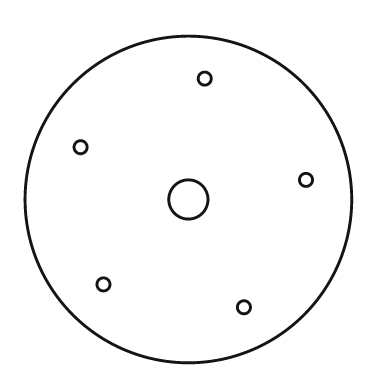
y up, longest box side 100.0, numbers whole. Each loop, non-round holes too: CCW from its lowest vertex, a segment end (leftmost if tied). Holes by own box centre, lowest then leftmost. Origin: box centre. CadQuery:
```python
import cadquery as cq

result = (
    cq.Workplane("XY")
    .moveTo(0.0, 0.0)
    .circle(50.0)
    .moveTo(17.0, -33.0)
    .circle(2.0)
    .moveTo(-26.0, -26.0)
    .circle(2.0)
    .moveTo(0.0, 0.0)
    .circle(6.0)
    .moveTo(36.0, 6.0)
    .circle(2.0)
    .moveTo(-33.0, 16.0)
    .circle(2.0)
    .moveTo(5.0, 37.0)
    .circle(2.0)
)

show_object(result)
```